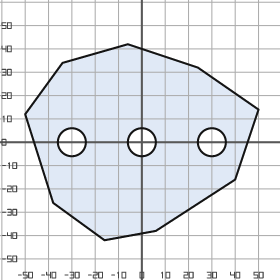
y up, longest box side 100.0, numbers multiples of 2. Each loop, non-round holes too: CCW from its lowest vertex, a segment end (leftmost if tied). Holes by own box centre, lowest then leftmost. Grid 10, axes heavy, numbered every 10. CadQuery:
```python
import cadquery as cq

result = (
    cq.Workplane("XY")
    .moveTo(-16.0, -42.0)
    .lineTo(6.0, -38.0)
    .lineTo(40.0, -16.0)
    .lineTo(50.0, 14.0)
    .lineTo(24.0, 32.0)
    .lineTo(-6.0, 42.0)
    .lineTo(-34.0, 34.0)
    .lineTo(-50.0, 12.0)
    .lineTo(-38.0, -26.0)
    .close()
    .moveTo(-30.0, 0.0)
    .circle(6.0)
    .moveTo(0.0, 0.0)
    .circle(6.0)
    .moveTo(30.0, 0.0)
    .circle(6.0)
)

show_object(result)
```